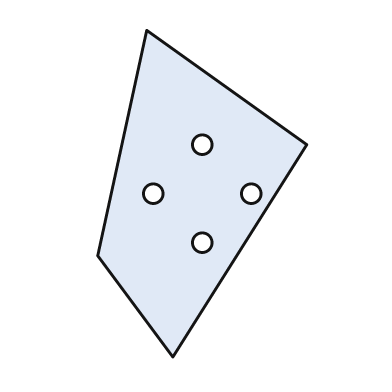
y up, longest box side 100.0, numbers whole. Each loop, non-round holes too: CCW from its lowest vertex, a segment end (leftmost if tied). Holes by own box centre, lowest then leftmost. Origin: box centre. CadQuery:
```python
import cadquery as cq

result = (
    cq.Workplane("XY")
    .moveTo(-9.0, -50.0)
    .lineTo(32.0, 15.0)
    .lineTo(-17.0, 50.0)
    .lineTo(-32.0, -19.0)
    .close()
    .moveTo(0.0, -15.0)
    .circle(3.0)
    .moveTo(-15.0, 0.0)
    .circle(3.0)
    .moveTo(15.0, 0.0)
    .circle(3.0)
    .moveTo(0.0, 15.0)
    .circle(3.0)
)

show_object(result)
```